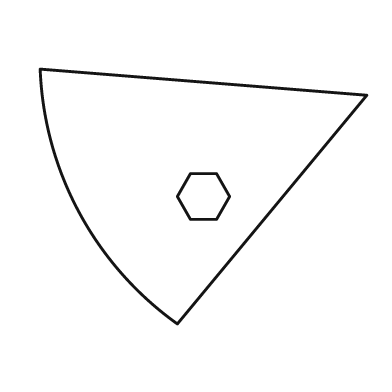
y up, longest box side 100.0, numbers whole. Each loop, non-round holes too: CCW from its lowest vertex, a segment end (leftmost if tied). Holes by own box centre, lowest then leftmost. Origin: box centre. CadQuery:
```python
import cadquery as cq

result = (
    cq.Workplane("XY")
    .moveTo(-8.0, -39.0)
    .lineTo(50.0, 31.0)
    .lineTo(-50.0, 39.0)
    .threePointArc((-38.0, -5.0), (-8.0, -39.0))
    .close()
    .moveTo(-4.0, -7.0)
    .lineTo(4.0, -7.0)
    .lineTo(8.0, 0.0)
    .lineTo(4.0, 7.0)
    .lineTo(-4.0, 7.0)
    .lineTo(-8.0, 0.0)
    .close()
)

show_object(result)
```